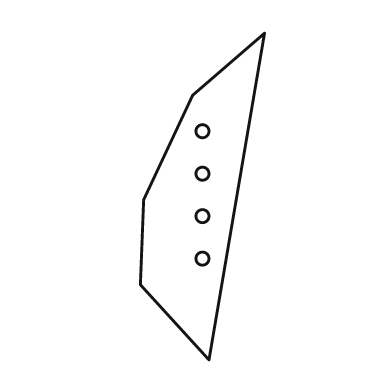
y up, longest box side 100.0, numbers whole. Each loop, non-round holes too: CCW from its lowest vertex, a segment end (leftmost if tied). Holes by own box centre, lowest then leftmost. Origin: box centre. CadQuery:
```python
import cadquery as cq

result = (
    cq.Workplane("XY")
    .moveTo(2.0, -50.0)
    .lineTo(19.0, 50.0)
    .lineTo(-3.0, 31.0)
    .lineTo(-18.0, -1.0)
    .lineTo(-19.0, -27.0)
    .close()
    .moveTo(0.0, -19.0)
    .circle(2.0)
    .moveTo(0.0, -6.0)
    .circle(2.0)
    .moveTo(0.0, 7.0)
    .circle(2.0)
    .moveTo(0.0, 20.0)
    .circle(2.0)
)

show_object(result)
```